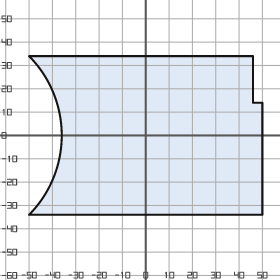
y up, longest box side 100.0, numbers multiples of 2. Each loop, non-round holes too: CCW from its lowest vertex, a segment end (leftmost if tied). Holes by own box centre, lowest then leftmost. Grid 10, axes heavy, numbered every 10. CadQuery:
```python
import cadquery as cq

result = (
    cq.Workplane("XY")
    .moveTo(-50.0, -34.0)
    .lineTo(50.0, -34.0)
    .lineTo(50.0, 14.0)
    .lineTo(46.0, 14.0)
    .lineTo(46.0, 34.0)
    .lineTo(-50.0, 34.0)
    .threePointArc((-36.0, 0.0), (-50.0, -34.0))
    .close()
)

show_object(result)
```